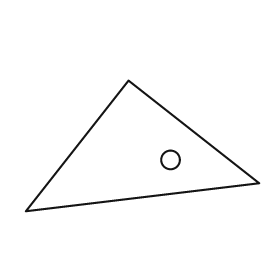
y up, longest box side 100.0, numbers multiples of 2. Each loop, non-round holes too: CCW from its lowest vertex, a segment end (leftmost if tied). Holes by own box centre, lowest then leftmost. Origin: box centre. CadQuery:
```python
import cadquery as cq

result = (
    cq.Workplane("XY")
    .moveTo(-50.0, -28.0)
    .lineTo(50.0, -16.0)
    .lineTo(-6.0, 28.0)
    .close()
    .moveTo(12.0, -6.0)
    .circle(4.0)
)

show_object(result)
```